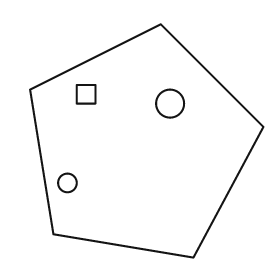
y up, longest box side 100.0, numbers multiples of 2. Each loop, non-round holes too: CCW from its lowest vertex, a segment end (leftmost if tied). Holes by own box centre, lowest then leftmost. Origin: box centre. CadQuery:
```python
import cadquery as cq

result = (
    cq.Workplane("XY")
    .moveTo(20.0, -50.0)
    .lineTo(50.0, 6.0)
    .lineTo(6.0, 50.0)
    .lineTo(-50.0, 22.0)
    .lineTo(-40.0, -40.0)
    .close()
    .moveTo(-34.0, -18.0)
    .circle(4.0)
    .moveTo(10.0, 16.0)
    .circle(6.0)
    .moveTo(-30.0, 16.0)
    .lineTo(-22.0, 16.0)
    .lineTo(-22.0, 24.0)
    .lineTo(-30.0, 24.0)
    .close()
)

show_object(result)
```